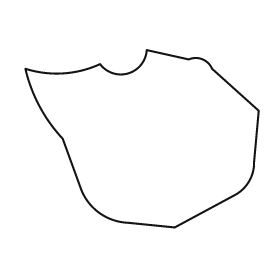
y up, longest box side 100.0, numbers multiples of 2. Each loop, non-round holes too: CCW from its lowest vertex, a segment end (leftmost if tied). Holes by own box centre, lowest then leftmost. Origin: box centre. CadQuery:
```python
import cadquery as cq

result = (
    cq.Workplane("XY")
    .moveTo(14.0, -38.0)
    .lineTo(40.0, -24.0)
    .threePointArc((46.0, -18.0), (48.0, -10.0))
    .lineTo(50.0, 12.0)
    .lineTo(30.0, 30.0)
    .threePointArc((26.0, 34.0), (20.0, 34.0))
    .lineTo(2.0, 38.0)
    .threePointArc((-6.0, 28.0), (-18.0, 32.0))
    .threePointArc((-34.0, 28.0), (-50.0, 30.0))
    .threePointArc((-44.0, 14.0), (-34.0, 0.0))
    .lineTo(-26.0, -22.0)
    .threePointArc((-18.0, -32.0), (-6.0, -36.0))
    .close()
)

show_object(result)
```